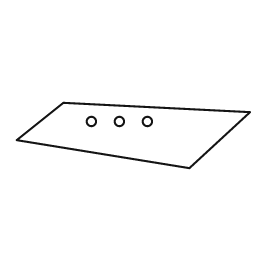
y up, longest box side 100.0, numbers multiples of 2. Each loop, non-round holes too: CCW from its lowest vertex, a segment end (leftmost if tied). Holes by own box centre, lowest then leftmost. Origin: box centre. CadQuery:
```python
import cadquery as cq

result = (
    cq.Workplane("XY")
    .moveTo(24.0, -14.0)
    .lineTo(50.0, 10.0)
    .lineTo(-30.0, 14.0)
    .lineTo(-50.0, -2.0)
    .close()
    .moveTo(-18.0, 6.0)
    .circle(2.0)
    .moveTo(-6.0, 6.0)
    .circle(2.0)
    .moveTo(6.0, 6.0)
    .circle(2.0)
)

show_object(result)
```